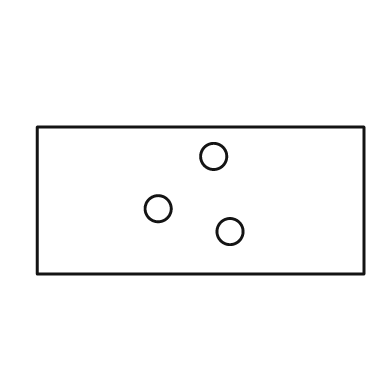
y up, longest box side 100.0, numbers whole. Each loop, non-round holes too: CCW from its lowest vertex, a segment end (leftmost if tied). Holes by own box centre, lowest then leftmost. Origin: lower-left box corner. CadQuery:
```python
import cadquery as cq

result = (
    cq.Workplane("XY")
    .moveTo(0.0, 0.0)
    .lineTo(100.0, 0.0)
    .lineTo(100.0, 45.0)
    .lineTo(0.0, 45.0)
    .close()
    .moveTo(59.0, 13.0)
    .circle(4.0)
    .moveTo(37.0, 20.0)
    .circle(4.0)
    .moveTo(54.0, 36.0)
    .circle(4.0)
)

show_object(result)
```